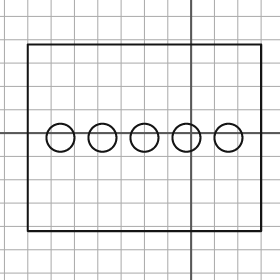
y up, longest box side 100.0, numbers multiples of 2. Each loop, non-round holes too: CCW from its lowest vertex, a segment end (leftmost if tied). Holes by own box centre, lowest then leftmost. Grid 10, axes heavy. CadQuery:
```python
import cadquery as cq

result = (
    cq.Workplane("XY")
    .moveTo(-70.0, -42.0)
    .lineTo(30.0, -42.0)
    .lineTo(30.0, 38.0)
    .lineTo(-70.0, 38.0)
    .close()
    .moveTo(-56.0, -2.0)
    .circle(6.0)
    .moveTo(-38.0, -2.0)
    .circle(6.0)
    .moveTo(-20.0, -2.0)
    .circle(6.0)
    .moveTo(-2.0, -2.0)
    .circle(6.0)
    .moveTo(16.0, -2.0)
    .circle(6.0)
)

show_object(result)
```